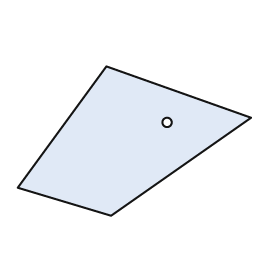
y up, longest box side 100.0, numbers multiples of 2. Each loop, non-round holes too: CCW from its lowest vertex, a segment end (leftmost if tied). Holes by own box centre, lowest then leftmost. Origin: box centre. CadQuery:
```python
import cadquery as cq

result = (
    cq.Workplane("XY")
    .moveTo(-10.0, -32.0)
    .lineTo(50.0, 10.0)
    .lineTo(-12.0, 32.0)
    .lineTo(-50.0, -20.0)
    .close()
    .moveTo(14.0, 8.0)
    .circle(2.0)
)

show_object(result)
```